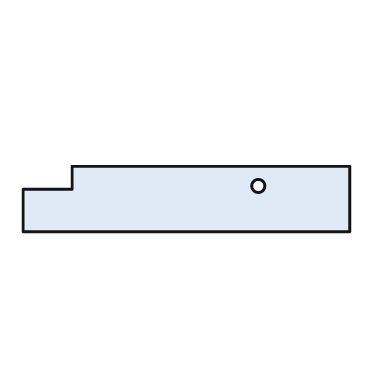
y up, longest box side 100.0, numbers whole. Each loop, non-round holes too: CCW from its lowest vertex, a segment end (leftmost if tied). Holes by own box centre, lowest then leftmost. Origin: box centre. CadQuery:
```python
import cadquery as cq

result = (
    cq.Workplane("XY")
    .moveTo(-50.0, -10.0)
    .lineTo(50.0, -10.0)
    .lineTo(50.0, 10.0)
    .lineTo(-35.0, 10.0)
    .lineTo(-35.0, 3.0)
    .lineTo(-50.0, 3.0)
    .close()
    .moveTo(22.0, 4.0)
    .circle(2.0)
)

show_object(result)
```